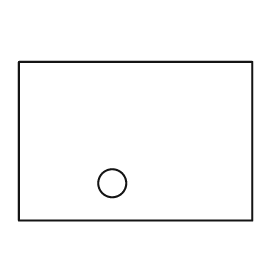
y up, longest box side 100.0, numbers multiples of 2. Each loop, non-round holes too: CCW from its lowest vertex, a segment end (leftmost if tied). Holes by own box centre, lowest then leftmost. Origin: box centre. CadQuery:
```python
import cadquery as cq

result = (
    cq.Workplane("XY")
    .moveTo(-50.0, -34.0)
    .lineTo(50.0, -34.0)
    .lineTo(50.0, 34.0)
    .lineTo(-50.0, 34.0)
    .close()
    .moveTo(-10.0, -18.0)
    .circle(6.0)
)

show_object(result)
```